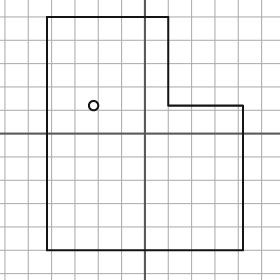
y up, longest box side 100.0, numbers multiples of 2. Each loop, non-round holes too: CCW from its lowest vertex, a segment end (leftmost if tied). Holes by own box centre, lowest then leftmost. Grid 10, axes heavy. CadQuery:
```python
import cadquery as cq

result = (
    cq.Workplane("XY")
    .moveTo(-42.0, -50.0)
    .lineTo(42.0, -50.0)
    .lineTo(42.0, 12.0)
    .lineTo(10.0, 12.0)
    .lineTo(10.0, 50.0)
    .lineTo(-42.0, 50.0)
    .close()
    .moveTo(-22.0, 12.0)
    .circle(2.0)
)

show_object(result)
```